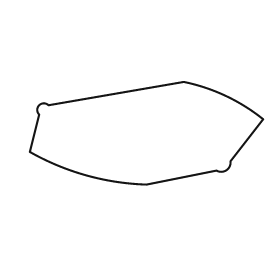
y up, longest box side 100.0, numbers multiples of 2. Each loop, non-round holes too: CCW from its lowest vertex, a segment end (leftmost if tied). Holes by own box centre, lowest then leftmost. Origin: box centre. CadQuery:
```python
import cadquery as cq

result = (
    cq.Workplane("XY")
    .moveTo(0.0, -22.0)
    .lineTo(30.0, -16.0)
    .threePointArc((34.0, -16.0), (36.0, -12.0))
    .lineTo(50.0, 6.0)
    .threePointArc((34.0, 16.0), (16.0, 22.0))
    .lineTo(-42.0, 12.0)
    .threePointArc((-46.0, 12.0), (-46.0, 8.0))
    .lineTo(-50.0, -8.0)
    .threePointArc((-26.0, -18.0), (0.0, -22.0))
    .close()
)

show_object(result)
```